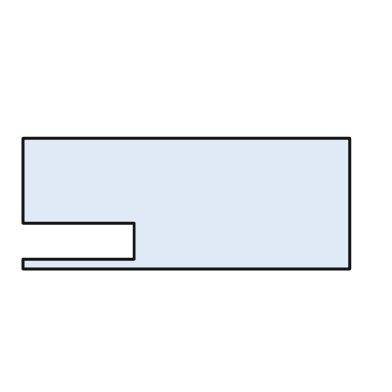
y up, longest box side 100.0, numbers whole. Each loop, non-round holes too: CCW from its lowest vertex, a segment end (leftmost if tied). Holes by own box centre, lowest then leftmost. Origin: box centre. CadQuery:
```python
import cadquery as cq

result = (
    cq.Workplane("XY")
    .moveTo(-50.0, -20.0)
    .lineTo(50.0, -20.0)
    .lineTo(50.0, 20.0)
    .lineTo(-50.0, 20.0)
    .lineTo(-50.0, -6.0)
    .lineTo(-16.0, -6.0)
    .lineTo(-16.0, -17.0)
    .lineTo(-50.0, -17.0)
    .close()
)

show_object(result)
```